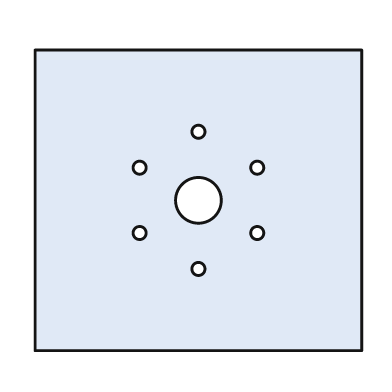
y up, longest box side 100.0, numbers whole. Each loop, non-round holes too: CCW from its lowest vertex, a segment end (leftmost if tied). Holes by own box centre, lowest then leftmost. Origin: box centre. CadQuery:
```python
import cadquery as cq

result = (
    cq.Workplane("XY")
    .moveTo(-50.0, -46.0)
    .lineTo(50.0, -46.0)
    .lineTo(50.0, 46.0)
    .lineTo(-50.0, 46.0)
    .close()
    .moveTo(0.0, -21.0)
    .circle(2.0)
    .moveTo(-18.0, -10.0)
    .circle(2.0)
    .moveTo(18.0, -10.0)
    .circle(2.0)
    .moveTo(0.0, 0.0)
    .circle(7.0)
    .moveTo(-18.0, 10.0)
    .circle(2.0)
    .moveTo(18.0, 10.0)
    .circle(2.0)
    .moveTo(0.0, 21.0)
    .circle(2.0)
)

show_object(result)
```